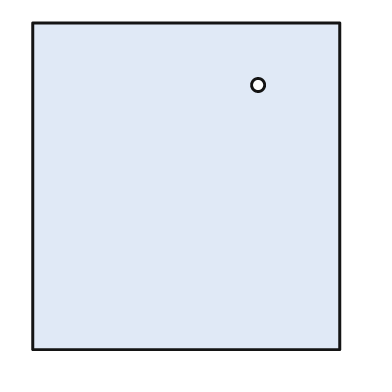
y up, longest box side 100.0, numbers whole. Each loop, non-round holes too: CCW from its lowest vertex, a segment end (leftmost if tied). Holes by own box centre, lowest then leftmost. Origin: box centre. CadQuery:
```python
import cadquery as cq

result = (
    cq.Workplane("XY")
    .moveTo(-47.0, -50.0)
    .lineTo(47.0, -50.0)
    .lineTo(47.0, 50.0)
    .lineTo(-47.0, 50.0)
    .close()
    .moveTo(22.0, 31.0)
    .circle(2.0)
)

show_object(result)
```